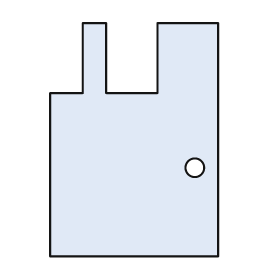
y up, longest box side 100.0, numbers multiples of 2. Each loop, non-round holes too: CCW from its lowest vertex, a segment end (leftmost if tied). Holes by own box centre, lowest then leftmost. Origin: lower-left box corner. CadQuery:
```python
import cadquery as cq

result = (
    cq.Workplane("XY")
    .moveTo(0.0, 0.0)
    .lineTo(72.0, 0.0)
    .lineTo(72.0, 100.0)
    .lineTo(46.0, 100.0)
    .lineTo(46.0, 70.0)
    .lineTo(24.0, 70.0)
    .lineTo(24.0, 100.0)
    .lineTo(14.0, 100.0)
    .lineTo(14.0, 70.0)
    .lineTo(0.0, 70.0)
    .close()
    .moveTo(62.0, 38.0)
    .circle(4.0)
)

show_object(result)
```